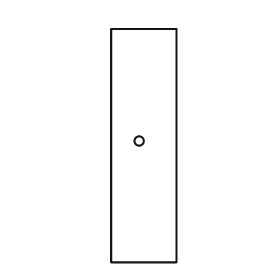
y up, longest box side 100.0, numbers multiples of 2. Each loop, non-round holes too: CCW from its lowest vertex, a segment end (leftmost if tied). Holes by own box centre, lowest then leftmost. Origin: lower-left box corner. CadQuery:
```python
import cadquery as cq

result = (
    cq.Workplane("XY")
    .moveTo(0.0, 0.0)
    .lineTo(28.0, 0.0)
    .lineTo(28.0, 100.0)
    .lineTo(0.0, 100.0)
    .close()
    .moveTo(12.0, 52.0)
    .circle(2.0)
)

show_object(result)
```